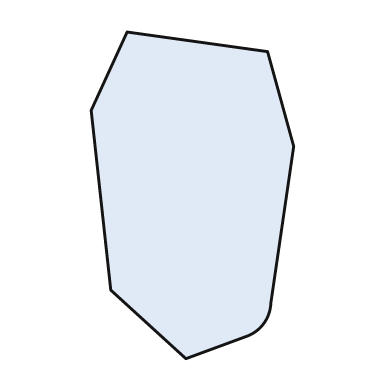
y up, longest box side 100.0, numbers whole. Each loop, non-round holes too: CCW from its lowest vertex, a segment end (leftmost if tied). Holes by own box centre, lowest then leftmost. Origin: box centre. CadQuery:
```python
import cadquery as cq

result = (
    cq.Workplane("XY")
    .moveTo(-2.0, -50.0)
    .lineTo(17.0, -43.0)
    .threePointArc((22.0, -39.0), (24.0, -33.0))
    .lineTo(31.0, 15.0)
    .lineTo(23.0, 44.0)
    .lineTo(-20.0, 50.0)
    .lineTo(-31.0, 26.0)
    .lineTo(-25.0, -29.0)
    .close()
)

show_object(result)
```